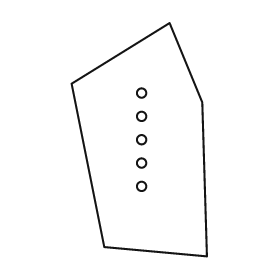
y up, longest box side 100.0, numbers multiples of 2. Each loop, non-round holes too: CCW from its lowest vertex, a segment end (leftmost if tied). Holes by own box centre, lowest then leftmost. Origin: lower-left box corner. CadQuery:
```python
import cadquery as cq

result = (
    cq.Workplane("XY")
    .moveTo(58.0, 0.0)
    .lineTo(56.0, 66.0)
    .lineTo(42.0, 100.0)
    .lineTo(0.0, 74.0)
    .lineTo(14.0, 4.0)
    .close()
    .moveTo(30.0, 30.0)
    .circle(2.0)
    .moveTo(30.0, 40.0)
    .circle(2.0)
    .moveTo(30.0, 50.0)
    .circle(2.0)
    .moveTo(30.0, 60.0)
    .circle(2.0)
    .moveTo(30.0, 70.0)
    .circle(2.0)
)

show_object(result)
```